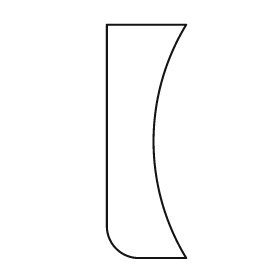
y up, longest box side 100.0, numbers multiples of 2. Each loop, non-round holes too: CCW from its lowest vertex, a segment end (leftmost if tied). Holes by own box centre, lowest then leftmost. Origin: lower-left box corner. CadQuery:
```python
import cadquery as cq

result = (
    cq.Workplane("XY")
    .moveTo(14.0, 0.0)
    .lineTo(34.0, 0.0)
    .threePointArc((20.0, 50.0), (34.0, 100.0))
    .lineTo(0.0, 100.0)
    .lineTo(0.0, 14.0)
    .threePointArc((4.0, 4.0), (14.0, 0.0))
    .close()
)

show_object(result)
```